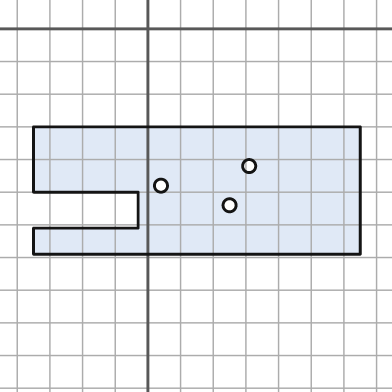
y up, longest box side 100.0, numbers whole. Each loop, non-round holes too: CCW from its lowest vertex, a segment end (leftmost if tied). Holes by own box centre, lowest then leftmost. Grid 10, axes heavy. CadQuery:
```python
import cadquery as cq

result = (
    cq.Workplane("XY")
    .moveTo(-35.0, -69.0)
    .lineTo(65.0, -69.0)
    .lineTo(65.0, -30.0)
    .lineTo(-35.0, -30.0)
    .lineTo(-35.0, -50.0)
    .lineTo(-3.0, -50.0)
    .lineTo(-3.0, -61.0)
    .lineTo(-35.0, -61.0)
    .close()
    .moveTo(25.0, -54.0)
    .circle(2.0)
    .moveTo(4.0, -48.0)
    .circle(2.0)
    .moveTo(31.0, -42.0)
    .circle(2.0)
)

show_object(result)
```